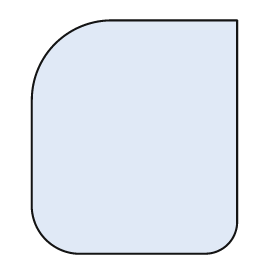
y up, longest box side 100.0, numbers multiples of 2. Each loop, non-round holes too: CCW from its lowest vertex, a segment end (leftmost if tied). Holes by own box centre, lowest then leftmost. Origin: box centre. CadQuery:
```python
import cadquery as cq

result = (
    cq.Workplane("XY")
    .moveTo(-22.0, -50.0)
    .lineTo(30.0, -50.0)
    .threePointArc((40.0, -46.0), (44.0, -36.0))
    .lineTo(44.0, 50.0)
    .lineTo(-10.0, 50.0)
    .threePointArc((-34.0, 40.0), (-44.0, 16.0))
    .lineTo(-44.0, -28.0)
    .threePointArc((-38.0, -44.0), (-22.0, -50.0))
    .close()
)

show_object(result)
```